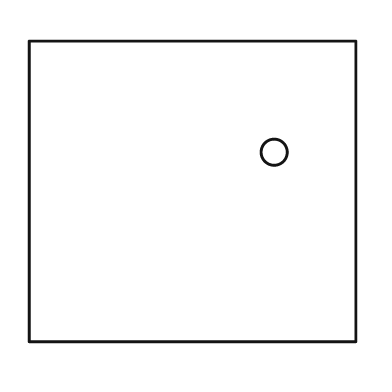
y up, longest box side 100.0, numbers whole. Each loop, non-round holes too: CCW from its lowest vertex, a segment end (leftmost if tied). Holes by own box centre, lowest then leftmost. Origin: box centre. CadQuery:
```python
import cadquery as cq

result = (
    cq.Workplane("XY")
    .moveTo(-50.0, -46.0)
    .lineTo(50.0, -46.0)
    .lineTo(50.0, 46.0)
    .lineTo(-50.0, 46.0)
    .close()
    .moveTo(25.0, 12.0)
    .circle(4.0)
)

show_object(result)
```